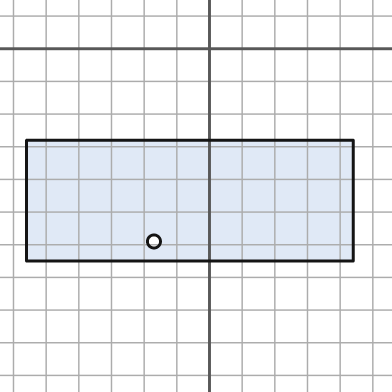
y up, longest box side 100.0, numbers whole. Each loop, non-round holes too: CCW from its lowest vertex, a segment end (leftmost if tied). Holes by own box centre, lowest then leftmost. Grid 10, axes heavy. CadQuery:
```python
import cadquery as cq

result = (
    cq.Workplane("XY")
    .moveTo(-56.0, -65.0)
    .lineTo(44.0, -65.0)
    .lineTo(44.0, -28.0)
    .lineTo(-56.0, -28.0)
    .close()
    .moveTo(-17.0, -59.0)
    .circle(2.0)
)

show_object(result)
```